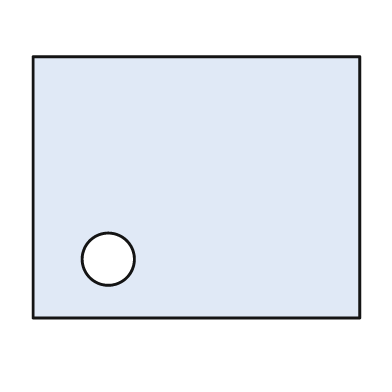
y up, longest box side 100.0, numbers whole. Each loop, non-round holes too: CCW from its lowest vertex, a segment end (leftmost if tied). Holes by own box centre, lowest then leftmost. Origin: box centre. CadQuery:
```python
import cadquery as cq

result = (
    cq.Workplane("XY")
    .moveTo(-50.0, -40.0)
    .lineTo(50.0, -40.0)
    .lineTo(50.0, 40.0)
    .lineTo(-50.0, 40.0)
    .close()
    .moveTo(-27.0, -22.0)
    .circle(8.0)
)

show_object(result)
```